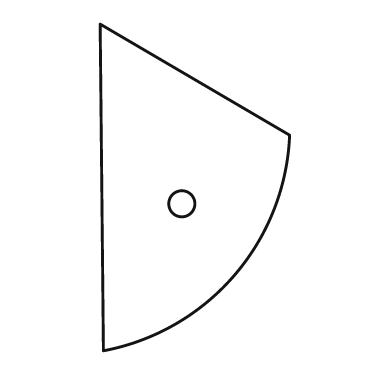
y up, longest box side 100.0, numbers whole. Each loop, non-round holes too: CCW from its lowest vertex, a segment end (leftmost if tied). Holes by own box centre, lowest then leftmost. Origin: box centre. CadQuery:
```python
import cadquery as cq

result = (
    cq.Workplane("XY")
    .moveTo(-28.0, -50.0)
    .threePointArc((12.0, -27.0), (29.0, 16.0))
    .lineTo(-29.0, 50.0)
    .close()
    .moveTo(-4.0, -5.0)
    .circle(4.0)
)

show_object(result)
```